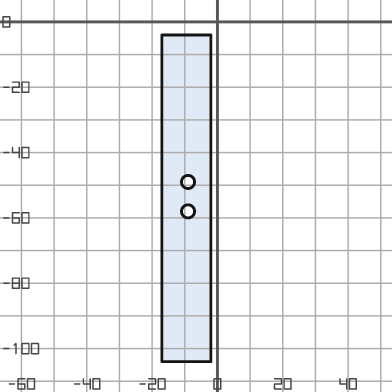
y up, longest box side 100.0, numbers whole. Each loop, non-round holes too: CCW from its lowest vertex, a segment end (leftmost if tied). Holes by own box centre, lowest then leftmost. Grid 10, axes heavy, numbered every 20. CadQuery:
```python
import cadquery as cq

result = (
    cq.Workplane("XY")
    .moveTo(-17.0, -104.0)
    .lineTo(-2.0, -104.0)
    .lineTo(-2.0, -4.0)
    .lineTo(-17.0, -4.0)
    .close()
    .moveTo(-9.0, -58.0)
    .circle(2.0)
    .moveTo(-9.0, -49.0)
    .circle(2.0)
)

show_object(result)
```